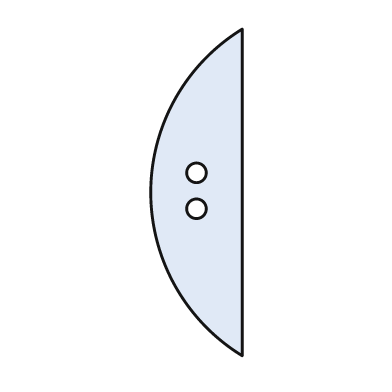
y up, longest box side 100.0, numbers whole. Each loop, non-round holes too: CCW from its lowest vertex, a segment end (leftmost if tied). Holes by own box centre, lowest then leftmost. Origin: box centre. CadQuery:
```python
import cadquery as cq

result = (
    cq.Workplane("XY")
    .moveTo(14.0, -50.0)
    .lineTo(14.0, 50.0)
    .threePointArc((-14.0, 0.0), (14.0, -50.0))
    .close()
    .moveTo(0.0, -5.0)
    .circle(3.0)
    .moveTo(0.0, 6.0)
    .circle(3.0)
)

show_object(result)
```